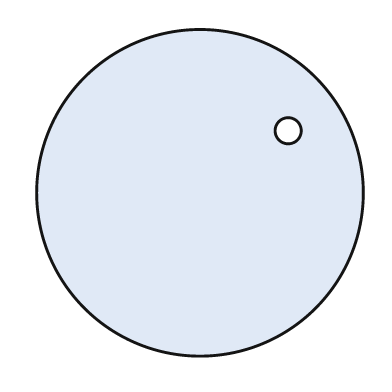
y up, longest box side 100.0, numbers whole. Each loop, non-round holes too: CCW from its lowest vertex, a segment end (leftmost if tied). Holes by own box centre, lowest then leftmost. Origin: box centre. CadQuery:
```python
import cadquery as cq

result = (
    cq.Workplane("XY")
    .moveTo(0.0, 0.0)
    .circle(50.0)
    .moveTo(27.0, 19.0)
    .circle(4.0)
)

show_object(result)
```